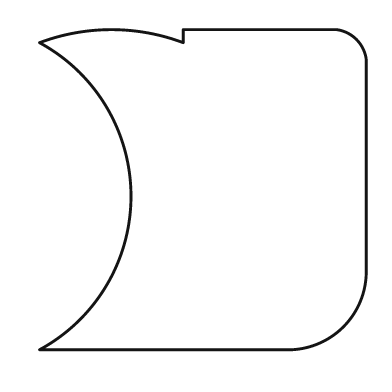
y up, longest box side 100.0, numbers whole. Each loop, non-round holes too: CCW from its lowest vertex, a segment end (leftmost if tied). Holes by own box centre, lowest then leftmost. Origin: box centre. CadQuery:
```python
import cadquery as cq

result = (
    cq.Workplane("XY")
    .moveTo(-50.0, -49.0)
    .lineTo(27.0, -49.0)
    .threePointArc((43.0, -42.0), (50.0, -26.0))
    .lineTo(50.0, 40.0)
    .threePointArc((47.0, 46.0), (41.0, 49.0))
    .lineTo(-6.0, 49.0)
    .lineTo(-6.0, 45.0)
    .threePointArc((-28.0, 49.0), (-50.0, 45.0))
    .threePointArc((-22.0, -2.0), (-50.0, -49.0))
    .close()
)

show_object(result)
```